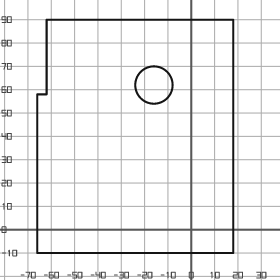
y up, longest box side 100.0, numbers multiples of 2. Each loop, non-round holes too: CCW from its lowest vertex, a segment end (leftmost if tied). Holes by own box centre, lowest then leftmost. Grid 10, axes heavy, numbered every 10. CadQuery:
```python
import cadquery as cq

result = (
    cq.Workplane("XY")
    .moveTo(-66.0, -10.0)
    .lineTo(18.0, -10.0)
    .lineTo(18.0, 90.0)
    .lineTo(-62.0, 90.0)
    .lineTo(-62.0, 58.0)
    .lineTo(-66.0, 58.0)
    .close()
    .moveTo(-16.0, 62.0)
    .circle(8.0)
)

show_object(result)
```